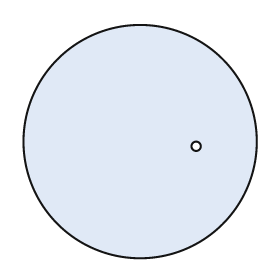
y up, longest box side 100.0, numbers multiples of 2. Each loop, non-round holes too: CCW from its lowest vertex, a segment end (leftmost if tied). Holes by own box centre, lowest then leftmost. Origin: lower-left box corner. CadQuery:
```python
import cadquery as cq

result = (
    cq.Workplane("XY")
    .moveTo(50.0, 50.0)
    .circle(50.0)
    .moveTo(74.0, 48.0)
    .circle(2.0)
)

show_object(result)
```